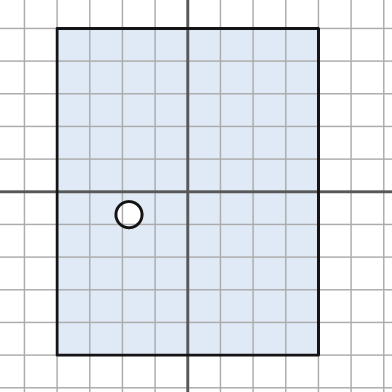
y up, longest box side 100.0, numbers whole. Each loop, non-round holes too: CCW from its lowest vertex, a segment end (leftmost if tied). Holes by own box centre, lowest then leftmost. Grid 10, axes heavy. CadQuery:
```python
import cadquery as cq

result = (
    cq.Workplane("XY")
    .moveTo(-40.0, -50.0)
    .lineTo(40.0, -50.0)
    .lineTo(40.0, 50.0)
    .lineTo(-40.0, 50.0)
    .close()
    .moveTo(-18.0, -7.0)
    .circle(4.0)
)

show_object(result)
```